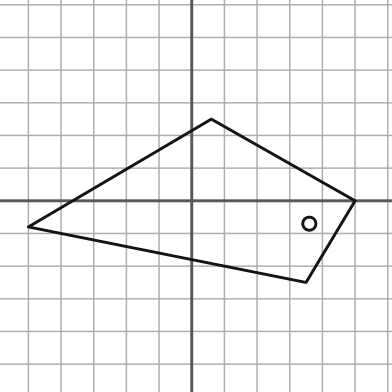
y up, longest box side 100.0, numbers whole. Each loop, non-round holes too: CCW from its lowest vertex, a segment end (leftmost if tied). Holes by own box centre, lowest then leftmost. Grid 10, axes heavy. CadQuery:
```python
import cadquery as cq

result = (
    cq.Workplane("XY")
    .moveTo(35.0, -25.0)
    .lineTo(50.0, 0.0)
    .lineTo(6.0, 25.0)
    .lineTo(-50.0, -8.0)
    .close()
    .moveTo(36.0, -7.0)
    .circle(2.0)
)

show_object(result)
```